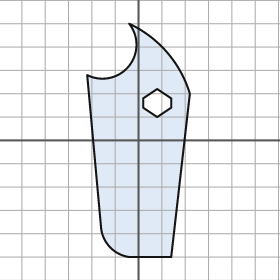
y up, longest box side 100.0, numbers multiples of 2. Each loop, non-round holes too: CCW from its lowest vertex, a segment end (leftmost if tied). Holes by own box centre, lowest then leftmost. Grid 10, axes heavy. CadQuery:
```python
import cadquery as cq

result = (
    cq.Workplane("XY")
    .moveTo(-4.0, -50.0)
    .lineTo(14.0, -50.0)
    .lineTo(22.0, 20.0)
    .threePointArc((12.0, 38.0), (-4.0, 50.0))
    .threePointArc((-4.0, 32.0), (-22.0, 28.0))
    .lineTo(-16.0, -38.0)
    .threePointArc((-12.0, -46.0), (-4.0, -50.0))
    .close()
    .moveTo(8.0, 10.0)
    .lineTo(14.0, 14.0)
    .lineTo(14.0, 18.0)
    .lineTo(8.0, 22.0)
    .lineTo(2.0, 18.0)
    .lineTo(2.0, 14.0)
    .close()
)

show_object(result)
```